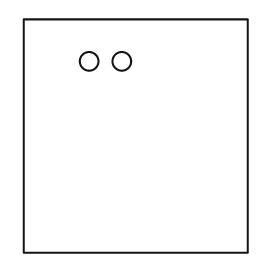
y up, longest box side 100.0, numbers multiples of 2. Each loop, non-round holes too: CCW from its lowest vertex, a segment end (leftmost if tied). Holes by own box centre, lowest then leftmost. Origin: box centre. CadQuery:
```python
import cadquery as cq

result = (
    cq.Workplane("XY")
    .moveTo(-48.0, -50.0)
    .lineTo(48.0, -50.0)
    .lineTo(48.0, 50.0)
    .lineTo(-48.0, 50.0)
    .close()
    .moveTo(-20.0, 32.0)
    .circle(4.0)
    .moveTo(-6.0, 32.0)
    .circle(4.0)
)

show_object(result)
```